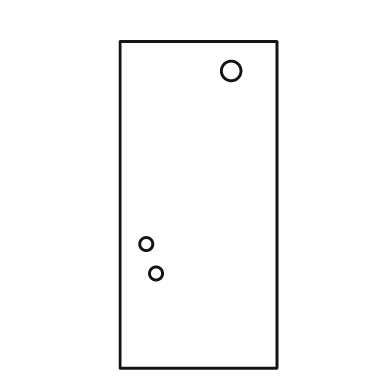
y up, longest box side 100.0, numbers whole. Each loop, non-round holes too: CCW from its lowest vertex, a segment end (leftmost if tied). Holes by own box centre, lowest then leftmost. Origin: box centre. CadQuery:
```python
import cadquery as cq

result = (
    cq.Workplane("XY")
    .moveTo(-24.0, -50.0)
    .lineTo(24.0, -50.0)
    .lineTo(24.0, 50.0)
    .lineTo(-24.0, 50.0)
    .close()
    .moveTo(-13.0, -21.0)
    .circle(2.0)
    .moveTo(-16.0, -12.0)
    .circle(2.0)
    .moveTo(10.0, 41.0)
    .circle(3.0)
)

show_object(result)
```